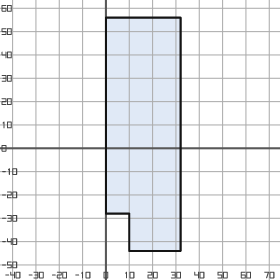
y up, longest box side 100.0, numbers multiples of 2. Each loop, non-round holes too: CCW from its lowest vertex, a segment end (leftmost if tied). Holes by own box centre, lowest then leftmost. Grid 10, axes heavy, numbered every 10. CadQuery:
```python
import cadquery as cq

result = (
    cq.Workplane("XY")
    .moveTo(10.0, -44.0)
    .lineTo(32.0, -44.0)
    .lineTo(32.0, 56.0)
    .lineTo(0.0, 56.0)
    .lineTo(0.0, -28.0)
    .lineTo(10.0, -28.0)
    .close()
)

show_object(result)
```